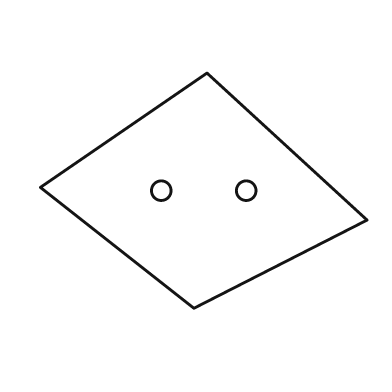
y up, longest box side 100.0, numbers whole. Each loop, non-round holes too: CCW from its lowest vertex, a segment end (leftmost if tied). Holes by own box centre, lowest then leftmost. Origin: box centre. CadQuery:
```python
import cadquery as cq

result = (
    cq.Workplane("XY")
    .moveTo(-3.0, -36.0)
    .lineTo(50.0, -9.0)
    .lineTo(1.0, 36.0)
    .lineTo(-50.0, 1.0)
    .close()
    .moveTo(-13.0, 0.0)
    .circle(3.0)
    .moveTo(13.0, 0.0)
    .circle(3.0)
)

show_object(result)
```